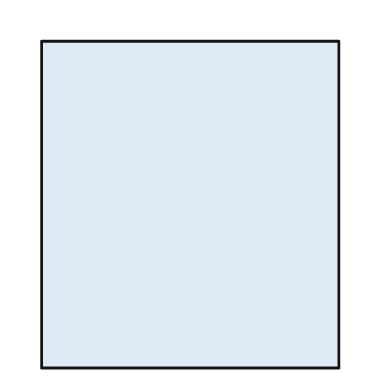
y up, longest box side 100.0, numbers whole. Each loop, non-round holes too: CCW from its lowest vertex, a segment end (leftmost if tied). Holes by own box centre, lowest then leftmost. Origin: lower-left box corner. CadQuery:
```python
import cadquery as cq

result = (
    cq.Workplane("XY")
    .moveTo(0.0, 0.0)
    .lineTo(91.0, 0.0)
    .lineTo(91.0, 100.0)
    .lineTo(0.0, 100.0)
    .close()
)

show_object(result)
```